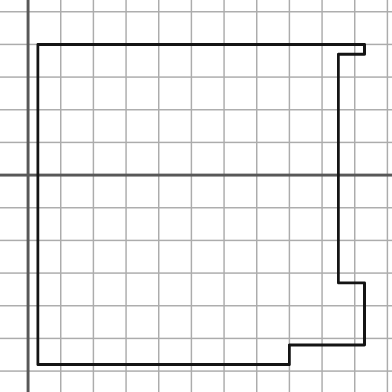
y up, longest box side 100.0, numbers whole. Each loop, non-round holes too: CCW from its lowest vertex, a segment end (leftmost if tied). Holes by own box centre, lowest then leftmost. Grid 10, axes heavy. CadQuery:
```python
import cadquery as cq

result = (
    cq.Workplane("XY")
    .moveTo(3.0, -58.0)
    .lineTo(80.0, -58.0)
    .lineTo(80.0, -52.0)
    .lineTo(103.0, -52.0)
    .lineTo(103.0, -33.0)
    .lineTo(95.0, -33.0)
    .lineTo(95.0, 37.0)
    .lineTo(103.0, 37.0)
    .lineTo(103.0, 40.0)
    .lineTo(3.0, 40.0)
    .close()
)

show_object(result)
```